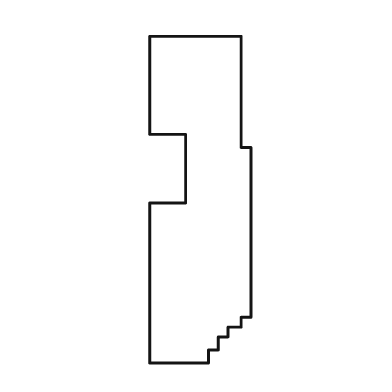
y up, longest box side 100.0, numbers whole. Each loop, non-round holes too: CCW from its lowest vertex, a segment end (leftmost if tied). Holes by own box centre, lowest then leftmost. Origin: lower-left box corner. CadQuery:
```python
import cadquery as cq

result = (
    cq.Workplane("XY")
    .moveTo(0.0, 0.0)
    .lineTo(18.0, 0.0)
    .lineTo(18.0, 4.0)
    .lineTo(21.0, 4.0)
    .lineTo(21.0, 8.0)
    .lineTo(24.0, 8.0)
    .lineTo(24.0, 11.0)
    .lineTo(28.0, 11.0)
    .lineTo(28.0, 14.0)
    .lineTo(31.0, 14.0)
    .lineTo(31.0, 66.0)
    .lineTo(28.0, 66.0)
    .lineTo(28.0, 100.0)
    .lineTo(0.0, 100.0)
    .lineTo(0.0, 70.0)
    .lineTo(11.0, 70.0)
    .lineTo(11.0, 49.0)
    .lineTo(0.0, 49.0)
    .close()
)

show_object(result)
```